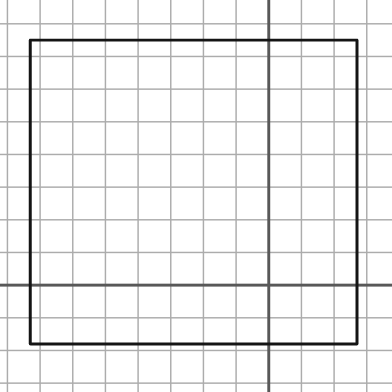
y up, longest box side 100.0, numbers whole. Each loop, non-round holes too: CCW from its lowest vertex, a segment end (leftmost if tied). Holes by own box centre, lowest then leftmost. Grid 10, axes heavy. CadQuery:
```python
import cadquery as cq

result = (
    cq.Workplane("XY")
    .moveTo(-73.0, -18.0)
    .lineTo(27.0, -18.0)
    .lineTo(27.0, 75.0)
    .lineTo(-73.0, 75.0)
    .close()
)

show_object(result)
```